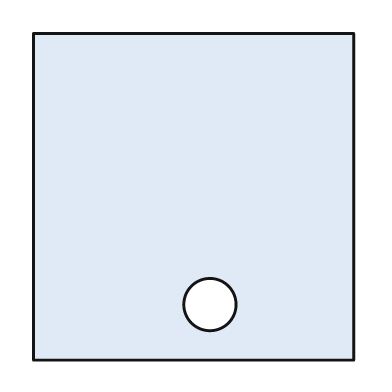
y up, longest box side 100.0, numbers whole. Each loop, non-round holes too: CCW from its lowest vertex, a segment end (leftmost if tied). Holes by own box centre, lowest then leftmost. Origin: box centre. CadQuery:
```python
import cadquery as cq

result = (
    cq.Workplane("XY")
    .moveTo(-49.0, -50.0)
    .lineTo(49.0, -50.0)
    .lineTo(49.0, 50.0)
    .lineTo(-49.0, 50.0)
    .close()
    .moveTo(5.0, -33.0)
    .circle(8.0)
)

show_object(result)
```